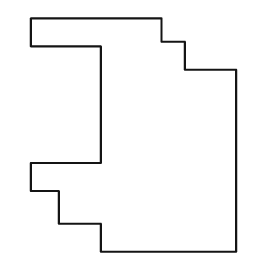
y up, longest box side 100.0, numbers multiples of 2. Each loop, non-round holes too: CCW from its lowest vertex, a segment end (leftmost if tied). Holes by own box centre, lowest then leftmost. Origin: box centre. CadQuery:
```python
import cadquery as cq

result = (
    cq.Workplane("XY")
    .moveTo(-14.0, -50.0)
    .lineTo(44.0, -50.0)
    .lineTo(44.0, 28.0)
    .lineTo(22.0, 28.0)
    .lineTo(22.0, 40.0)
    .lineTo(12.0, 40.0)
    .lineTo(12.0, 50.0)
    .lineTo(-44.0, 50.0)
    .lineTo(-44.0, 38.0)
    .lineTo(-14.0, 38.0)
    .lineTo(-14.0, -12.0)
    .lineTo(-44.0, -12.0)
    .lineTo(-44.0, -24.0)
    .lineTo(-32.0, -24.0)
    .lineTo(-32.0, -38.0)
    .lineTo(-14.0, -38.0)
    .close()
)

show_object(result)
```